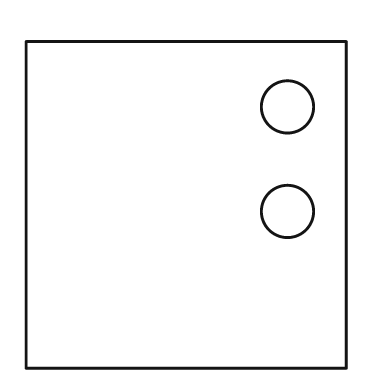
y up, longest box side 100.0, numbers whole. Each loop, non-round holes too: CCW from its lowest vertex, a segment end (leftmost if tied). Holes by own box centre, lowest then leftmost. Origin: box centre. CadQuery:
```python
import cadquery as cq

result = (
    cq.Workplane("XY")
    .moveTo(-49.0, -50.0)
    .lineTo(49.0, -50.0)
    .lineTo(49.0, 50.0)
    .lineTo(-49.0, 50.0)
    .close()
    .moveTo(31.0, -2.0)
    .circle(8.0)
    .moveTo(31.0, 30.0)
    .circle(8.0)
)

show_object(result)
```